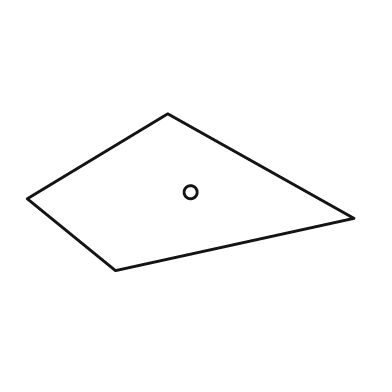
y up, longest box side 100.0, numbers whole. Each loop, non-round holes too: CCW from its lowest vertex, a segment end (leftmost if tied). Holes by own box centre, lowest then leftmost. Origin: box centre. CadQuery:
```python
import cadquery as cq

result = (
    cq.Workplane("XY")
    .moveTo(-23.0, -24.0)
    .lineTo(50.0, -8.0)
    .lineTo(-7.0, 24.0)
    .lineTo(-50.0, -2.0)
    .close()
    .moveTo(0.0, 0.0)
    .circle(2.0)
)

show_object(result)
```